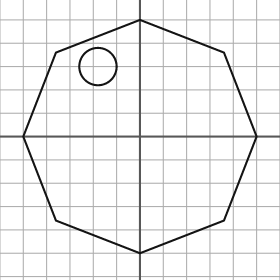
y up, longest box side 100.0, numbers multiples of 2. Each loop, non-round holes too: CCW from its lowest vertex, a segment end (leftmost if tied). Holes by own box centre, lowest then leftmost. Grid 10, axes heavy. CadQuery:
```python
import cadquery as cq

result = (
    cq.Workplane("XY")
    .moveTo(0.0, -50.0)
    .lineTo(36.0, -36.0)
    .lineTo(50.0, 0.0)
    .lineTo(36.0, 36.0)
    .lineTo(0.0, 50.0)
    .lineTo(-36.0, 36.0)
    .lineTo(-50.0, 0.0)
    .lineTo(-36.0, -36.0)
    .close()
    .moveTo(-18.0, 30.0)
    .circle(8.0)
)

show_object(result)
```